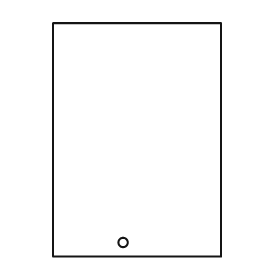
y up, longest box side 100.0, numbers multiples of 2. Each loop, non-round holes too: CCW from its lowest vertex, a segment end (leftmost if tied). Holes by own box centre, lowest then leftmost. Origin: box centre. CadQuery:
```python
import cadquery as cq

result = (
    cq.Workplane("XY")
    .moveTo(-36.0, -50.0)
    .lineTo(36.0, -50.0)
    .lineTo(36.0, 50.0)
    .lineTo(-36.0, 50.0)
    .close()
    .moveTo(-6.0, -44.0)
    .circle(2.0)
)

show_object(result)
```